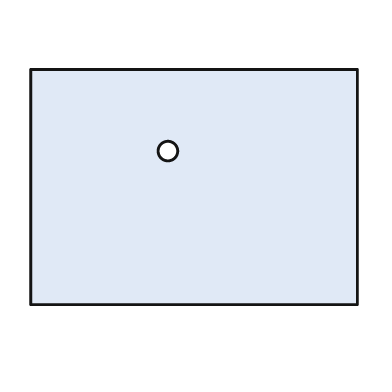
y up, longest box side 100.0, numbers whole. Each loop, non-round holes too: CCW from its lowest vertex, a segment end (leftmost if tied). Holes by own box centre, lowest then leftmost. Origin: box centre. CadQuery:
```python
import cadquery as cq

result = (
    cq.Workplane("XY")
    .moveTo(-50.0, -36.0)
    .lineTo(50.0, -36.0)
    .lineTo(50.0, 36.0)
    .lineTo(-50.0, 36.0)
    .close()
    .moveTo(-8.0, 11.0)
    .circle(3.0)
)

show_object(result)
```